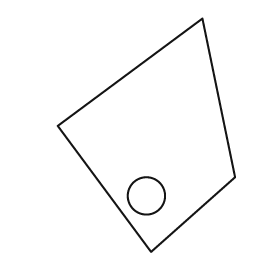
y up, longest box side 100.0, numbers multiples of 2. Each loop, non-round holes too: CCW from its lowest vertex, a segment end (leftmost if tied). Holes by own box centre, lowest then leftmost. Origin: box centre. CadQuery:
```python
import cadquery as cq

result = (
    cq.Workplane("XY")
    .moveTo(2.0, -50.0)
    .lineTo(38.0, -18.0)
    .lineTo(24.0, 50.0)
    .lineTo(-38.0, 4.0)
    .close()
    .moveTo(0.0, -26.0)
    .circle(8.0)
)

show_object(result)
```